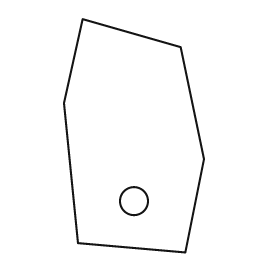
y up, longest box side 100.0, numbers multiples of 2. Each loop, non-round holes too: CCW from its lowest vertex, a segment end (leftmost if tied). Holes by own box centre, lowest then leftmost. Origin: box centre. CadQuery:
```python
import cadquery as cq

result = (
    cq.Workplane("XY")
    .moveTo(22.0, -50.0)
    .lineTo(30.0, -10.0)
    .lineTo(20.0, 38.0)
    .lineTo(-22.0, 50.0)
    .lineTo(-30.0, 14.0)
    .lineTo(-24.0, -46.0)
    .close()
    .moveTo(0.0, -28.0)
    .circle(6.0)
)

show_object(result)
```